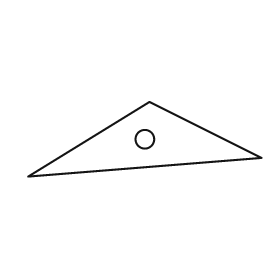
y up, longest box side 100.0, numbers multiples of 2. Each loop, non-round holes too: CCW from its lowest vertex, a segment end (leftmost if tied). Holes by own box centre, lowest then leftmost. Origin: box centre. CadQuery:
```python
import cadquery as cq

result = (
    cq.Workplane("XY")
    .moveTo(-50.0, -16.0)
    .lineTo(50.0, -8.0)
    .lineTo(2.0, 16.0)
    .close()
    .moveTo(0.0, 0.0)
    .circle(4.0)
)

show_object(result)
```